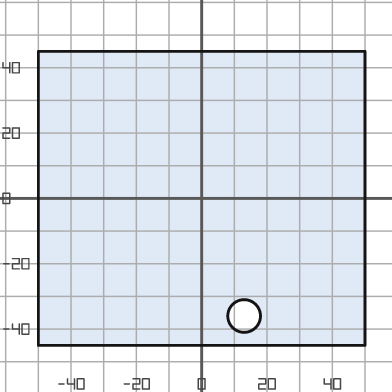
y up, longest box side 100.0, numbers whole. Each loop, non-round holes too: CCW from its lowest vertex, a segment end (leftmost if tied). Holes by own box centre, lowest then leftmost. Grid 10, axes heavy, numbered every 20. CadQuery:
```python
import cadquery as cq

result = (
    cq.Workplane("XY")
    .moveTo(-50.0, -45.0)
    .lineTo(50.0, -45.0)
    .lineTo(50.0, 45.0)
    .lineTo(-50.0, 45.0)
    .close()
    .moveTo(13.0, -36.0)
    .circle(5.0)
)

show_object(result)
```